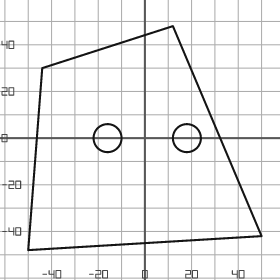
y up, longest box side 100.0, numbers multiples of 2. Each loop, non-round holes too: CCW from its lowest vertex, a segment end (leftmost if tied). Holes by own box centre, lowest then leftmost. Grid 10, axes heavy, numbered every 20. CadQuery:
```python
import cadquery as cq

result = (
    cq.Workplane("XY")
    .moveTo(-50.0, -48.0)
    .lineTo(50.0, -42.0)
    .lineTo(12.0, 48.0)
    .lineTo(-44.0, 30.0)
    .close()
    .moveTo(-16.0, 0.0)
    .circle(6.0)
    .moveTo(18.0, 0.0)
    .circle(6.0)
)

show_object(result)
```